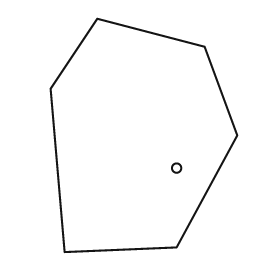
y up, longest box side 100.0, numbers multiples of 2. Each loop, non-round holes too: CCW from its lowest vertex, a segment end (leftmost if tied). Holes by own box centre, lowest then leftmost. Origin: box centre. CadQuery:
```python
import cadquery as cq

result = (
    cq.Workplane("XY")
    .moveTo(-34.0, -50.0)
    .lineTo(14.0, -48.0)
    .lineTo(40.0, 0.0)
    .lineTo(26.0, 38.0)
    .lineTo(-20.0, 50.0)
    .lineTo(-40.0, 20.0)
    .close()
    .moveTo(14.0, -14.0)
    .circle(2.0)
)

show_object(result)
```